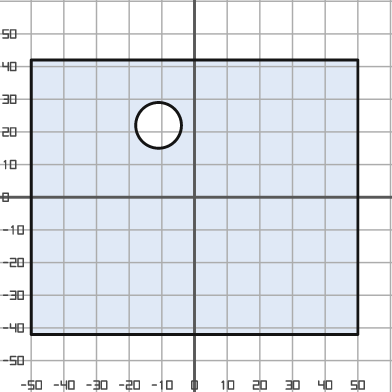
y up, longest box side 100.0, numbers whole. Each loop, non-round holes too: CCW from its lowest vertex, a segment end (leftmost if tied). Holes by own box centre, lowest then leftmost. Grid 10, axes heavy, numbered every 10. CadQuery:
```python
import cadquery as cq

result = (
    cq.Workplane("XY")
    .moveTo(-50.0, -42.0)
    .lineTo(50.0, -42.0)
    .lineTo(50.0, 42.0)
    .lineTo(-50.0, 42.0)
    .close()
    .moveTo(-11.0, 22.0)
    .circle(7.0)
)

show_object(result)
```